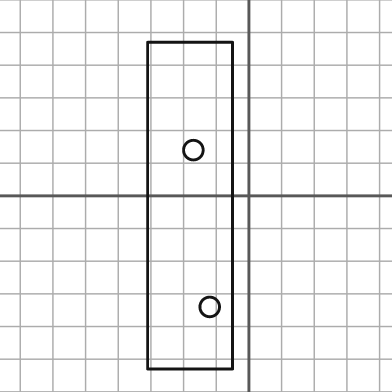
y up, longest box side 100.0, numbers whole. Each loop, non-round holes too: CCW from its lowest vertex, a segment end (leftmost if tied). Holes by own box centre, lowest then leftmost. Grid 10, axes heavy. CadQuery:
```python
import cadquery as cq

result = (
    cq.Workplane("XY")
    .moveTo(-31.0, -53.0)
    .lineTo(-5.0, -53.0)
    .lineTo(-5.0, 47.0)
    .lineTo(-31.0, 47.0)
    .close()
    .moveTo(-12.0, -34.0)
    .circle(3.0)
    .moveTo(-17.0, 14.0)
    .circle(3.0)
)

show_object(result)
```